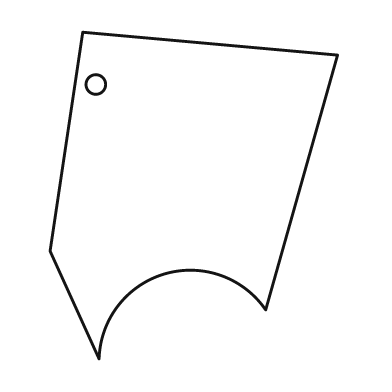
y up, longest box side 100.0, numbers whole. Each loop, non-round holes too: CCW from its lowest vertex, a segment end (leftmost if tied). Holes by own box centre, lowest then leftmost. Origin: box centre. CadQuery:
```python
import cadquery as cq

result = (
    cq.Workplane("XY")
    .moveTo(-29.0, -50.0)
    .threePointArc((-9.0, -24.0), (22.0, -35.0))
    .lineTo(44.0, 43.0)
    .lineTo(-34.0, 50.0)
    .lineTo(-44.0, -17.0)
    .close()
    .moveTo(-30.0, 34.0)
    .circle(3.0)
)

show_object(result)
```